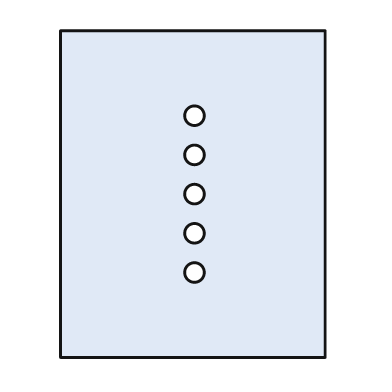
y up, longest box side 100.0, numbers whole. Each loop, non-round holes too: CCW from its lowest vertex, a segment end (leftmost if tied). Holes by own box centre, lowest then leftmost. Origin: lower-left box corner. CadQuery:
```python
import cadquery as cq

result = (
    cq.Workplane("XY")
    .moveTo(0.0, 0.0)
    .lineTo(81.0, 0.0)
    .lineTo(81.0, 100.0)
    .lineTo(0.0, 100.0)
    .close()
    .moveTo(41.0, 26.0)
    .circle(3.0)
    .moveTo(41.0, 38.0)
    .circle(3.0)
    .moveTo(41.0, 50.0)
    .circle(3.0)
    .moveTo(41.0, 62.0)
    .circle(3.0)
    .moveTo(41.0, 74.0)
    .circle(3.0)
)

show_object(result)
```